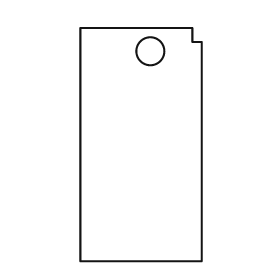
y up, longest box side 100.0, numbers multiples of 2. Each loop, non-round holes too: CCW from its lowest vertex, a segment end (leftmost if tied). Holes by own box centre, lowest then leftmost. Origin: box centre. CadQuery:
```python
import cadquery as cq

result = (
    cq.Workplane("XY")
    .moveTo(-26.0, -50.0)
    .lineTo(26.0, -50.0)
    .lineTo(26.0, 44.0)
    .lineTo(22.0, 44.0)
    .lineTo(22.0, 50.0)
    .lineTo(-26.0, 50.0)
    .close()
    .moveTo(4.0, 40.0)
    .circle(6.0)
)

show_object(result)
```